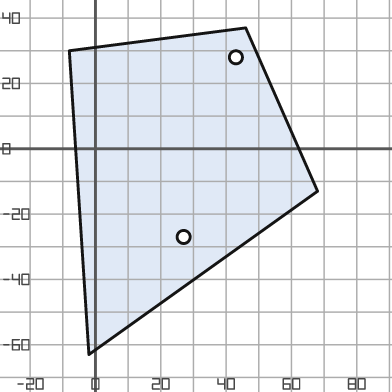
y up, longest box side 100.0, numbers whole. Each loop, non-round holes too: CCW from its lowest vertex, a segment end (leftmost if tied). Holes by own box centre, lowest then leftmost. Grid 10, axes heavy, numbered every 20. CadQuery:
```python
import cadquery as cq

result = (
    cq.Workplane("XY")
    .moveTo(-2.0, -63.0)
    .lineTo(68.0, -13.0)
    .lineTo(46.0, 37.0)
    .lineTo(-8.0, 30.0)
    .close()
    .moveTo(27.0, -27.0)
    .circle(2.0)
    .moveTo(43.0, 28.0)
    .circle(2.0)
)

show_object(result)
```